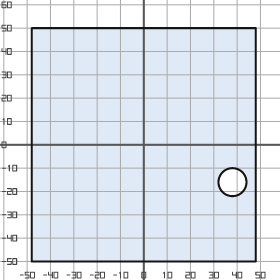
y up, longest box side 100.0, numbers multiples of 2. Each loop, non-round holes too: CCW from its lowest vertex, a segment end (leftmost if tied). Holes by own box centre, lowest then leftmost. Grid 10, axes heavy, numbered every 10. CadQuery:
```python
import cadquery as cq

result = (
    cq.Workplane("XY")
    .moveTo(-48.0, -50.0)
    .lineTo(48.0, -50.0)
    .lineTo(48.0, 50.0)
    .lineTo(-48.0, 50.0)
    .close()
    .moveTo(38.0, -16.0)
    .circle(6.0)
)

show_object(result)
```